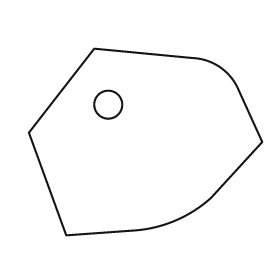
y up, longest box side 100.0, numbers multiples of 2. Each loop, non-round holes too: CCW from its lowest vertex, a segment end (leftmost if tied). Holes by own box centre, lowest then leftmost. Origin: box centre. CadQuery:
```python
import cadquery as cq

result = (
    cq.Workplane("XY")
    .moveTo(-34.0, -40.0)
    .lineTo(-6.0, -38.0)
    .threePointArc((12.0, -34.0), (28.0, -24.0))
    .lineTo(50.0, 0.0)
    .lineTo(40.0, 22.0)
    .threePointArc((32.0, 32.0), (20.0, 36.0))
    .lineTo(-22.0, 40.0)
    .lineTo(-50.0, 4.0)
    .close()
    .moveTo(-16.0, 16.0)
    .circle(6.0)
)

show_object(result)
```